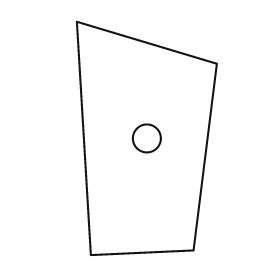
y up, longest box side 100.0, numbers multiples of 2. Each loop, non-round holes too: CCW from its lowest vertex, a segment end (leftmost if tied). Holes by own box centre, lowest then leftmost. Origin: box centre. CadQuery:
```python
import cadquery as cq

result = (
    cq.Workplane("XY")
    .moveTo(-24.0, -50.0)
    .lineTo(20.0, -48.0)
    .lineTo(30.0, 32.0)
    .lineTo(-30.0, 50.0)
    .close()
    .moveTo(0.0, 0.0)
    .circle(6.0)
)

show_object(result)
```